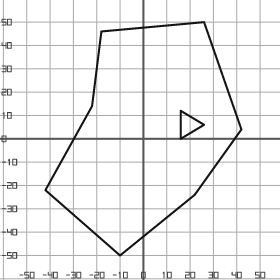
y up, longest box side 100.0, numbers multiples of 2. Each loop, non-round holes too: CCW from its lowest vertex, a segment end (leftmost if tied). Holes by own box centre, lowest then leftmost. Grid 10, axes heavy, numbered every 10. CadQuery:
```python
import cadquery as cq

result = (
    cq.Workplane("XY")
    .moveTo(-10.0, -50.0)
    .lineTo(22.0, -24.0)
    .lineTo(42.0, 4.0)
    .lineTo(26.0, 50.0)
    .lineTo(-18.0, 46.0)
    .lineTo(-22.0, 14.0)
    .lineTo(-42.0, -22.0)
    .close()
    .moveTo(16.0, 0.0)
    .lineTo(26.0, 6.0)
    .lineTo(16.0, 12.0)
    .close()
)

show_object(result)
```